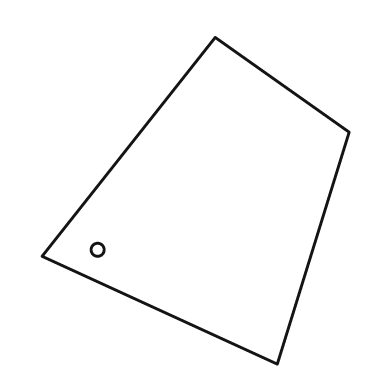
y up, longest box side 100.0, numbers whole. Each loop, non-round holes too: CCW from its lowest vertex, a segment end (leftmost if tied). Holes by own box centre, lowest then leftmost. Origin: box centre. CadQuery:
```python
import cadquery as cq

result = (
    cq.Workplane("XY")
    .moveTo(25.0, -50.0)
    .lineTo(47.0, 21.0)
    .lineTo(6.0, 50.0)
    .lineTo(-47.0, -17.0)
    .close()
    .moveTo(-30.0, -15.0)
    .circle(2.0)
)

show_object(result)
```